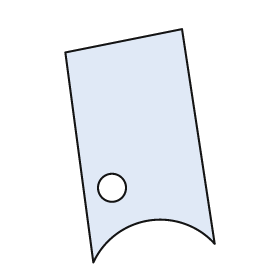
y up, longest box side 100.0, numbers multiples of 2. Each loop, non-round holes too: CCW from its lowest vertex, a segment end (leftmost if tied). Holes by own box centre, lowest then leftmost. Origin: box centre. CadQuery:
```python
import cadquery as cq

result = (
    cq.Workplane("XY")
    .moveTo(-20.0, -50.0)
    .threePointArc((4.0, -32.0), (32.0, -42.0))
    .lineTo(18.0, 50.0)
    .lineTo(-32.0, 40.0)
    .close()
    .moveTo(-12.0, -18.0)
    .circle(6.0)
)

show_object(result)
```